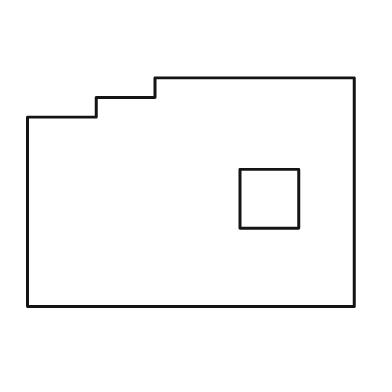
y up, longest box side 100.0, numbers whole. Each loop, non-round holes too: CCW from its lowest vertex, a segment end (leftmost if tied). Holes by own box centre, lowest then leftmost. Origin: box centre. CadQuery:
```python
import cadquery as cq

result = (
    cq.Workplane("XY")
    .moveTo(-50.0, -35.0)
    .lineTo(50.0, -35.0)
    .lineTo(50.0, 35.0)
    .lineTo(-11.0, 35.0)
    .lineTo(-11.0, 29.0)
    .lineTo(-29.0, 29.0)
    .lineTo(-29.0, 23.0)
    .lineTo(-50.0, 23.0)
    .close()
    .moveTo(15.0, -11.0)
    .lineTo(33.0, -11.0)
    .lineTo(33.0, 7.0)
    .lineTo(15.0, 7.0)
    .close()
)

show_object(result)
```